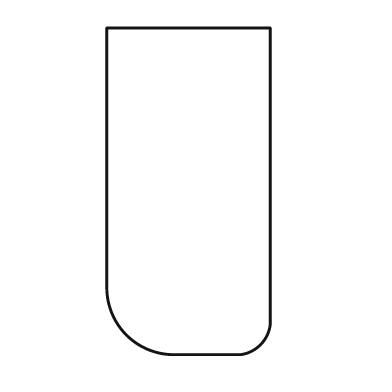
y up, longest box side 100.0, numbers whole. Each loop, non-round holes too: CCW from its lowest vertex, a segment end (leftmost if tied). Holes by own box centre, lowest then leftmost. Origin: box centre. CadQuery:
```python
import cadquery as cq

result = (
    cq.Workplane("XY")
    .moveTo(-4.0, -50.0)
    .lineTo(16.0, -50.0)
    .threePointArc((22.0, -47.0), (25.0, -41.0))
    .lineTo(25.0, 50.0)
    .lineTo(-25.0, 50.0)
    .lineTo(-25.0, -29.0)
    .threePointArc((-19.0, -44.0), (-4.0, -50.0))
    .close()
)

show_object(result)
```